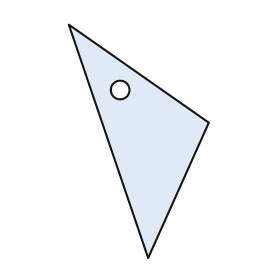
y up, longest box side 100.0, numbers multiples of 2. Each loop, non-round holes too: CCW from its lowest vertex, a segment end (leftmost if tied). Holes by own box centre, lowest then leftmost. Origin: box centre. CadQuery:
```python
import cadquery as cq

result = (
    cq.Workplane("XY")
    .moveTo(4.0, -50.0)
    .lineTo(30.0, 8.0)
    .lineTo(-30.0, 50.0)
    .close()
    .moveTo(-8.0, 22.0)
    .circle(4.0)
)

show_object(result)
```